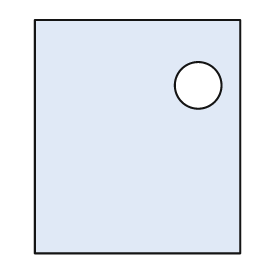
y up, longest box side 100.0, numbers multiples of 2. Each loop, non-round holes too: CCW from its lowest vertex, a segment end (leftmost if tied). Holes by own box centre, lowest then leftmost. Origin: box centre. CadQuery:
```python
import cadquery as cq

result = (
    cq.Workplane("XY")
    .moveTo(-44.0, -50.0)
    .lineTo(44.0, -50.0)
    .lineTo(44.0, 50.0)
    .lineTo(-44.0, 50.0)
    .close()
    .moveTo(26.0, 22.0)
    .circle(10.0)
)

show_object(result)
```